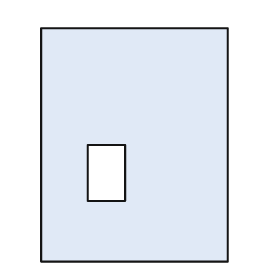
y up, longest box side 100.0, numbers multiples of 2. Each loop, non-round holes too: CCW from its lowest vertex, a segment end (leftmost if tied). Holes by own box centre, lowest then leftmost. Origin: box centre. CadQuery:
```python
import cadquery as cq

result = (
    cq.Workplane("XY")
    .moveTo(-40.0, -50.0)
    .lineTo(40.0, -50.0)
    .lineTo(40.0, 50.0)
    .lineTo(-40.0, 50.0)
    .close()
    .moveTo(-20.0, -24.0)
    .lineTo(-4.0, -24.0)
    .lineTo(-4.0, 0.0)
    .lineTo(-20.0, 0.0)
    .close()
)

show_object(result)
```